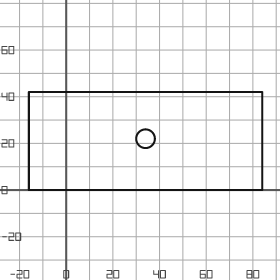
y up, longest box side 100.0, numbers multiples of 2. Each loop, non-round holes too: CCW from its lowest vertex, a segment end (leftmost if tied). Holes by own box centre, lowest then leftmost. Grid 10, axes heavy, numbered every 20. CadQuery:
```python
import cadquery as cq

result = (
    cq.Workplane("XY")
    .moveTo(-16.0, 0.0)
    .lineTo(84.0, 0.0)
    .lineTo(84.0, 42.0)
    .lineTo(-16.0, 42.0)
    .close()
    .moveTo(34.0, 22.0)
    .circle(4.0)
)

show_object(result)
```